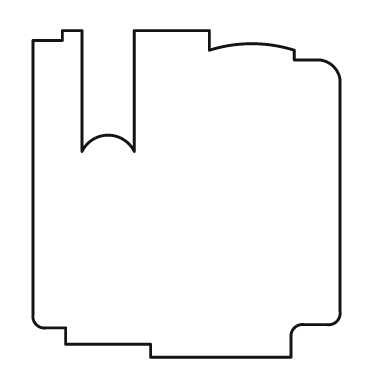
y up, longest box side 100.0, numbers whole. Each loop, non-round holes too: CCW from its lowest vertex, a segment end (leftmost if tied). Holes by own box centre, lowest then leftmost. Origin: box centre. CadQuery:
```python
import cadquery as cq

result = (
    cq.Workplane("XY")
    .moveTo(-11.0, -50.0)
    .lineTo(32.0, -50.0)
    .lineTo(32.0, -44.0)
    .threePointArc((33.0, -41.0), (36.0, -40.0))
    .lineTo(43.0, -40.0)
    .threePointArc((46.0, -39.0), (47.0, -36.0))
    .lineTo(47.0, 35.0)
    .threePointArc((45.0, 39.0), (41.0, 41.0))
    .lineTo(33.0, 41.0)
    .lineTo(33.0, 44.0)
    .threePointArc((20.0, 46.0), (7.0, 44.0))
    .lineTo(7.0, 50.0)
    .lineTo(-16.0, 50.0)
    .lineTo(-16.0, 13.0)
    .threePointArc((-24.0, 18.0), (-32.0, 13.0))
    .lineTo(-32.0, 50.0)
    .lineTo(-38.0, 50.0)
    .lineTo(-38.0, 47.0)
    .lineTo(-47.0, 47.0)
    .lineTo(-47.0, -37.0)
    .threePointArc((-46.0, -40.0), (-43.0, -41.0))
    .lineTo(-37.0, -41.0)
    .lineTo(-37.0, -46.0)
    .lineTo(-11.0, -46.0)
    .close()
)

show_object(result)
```